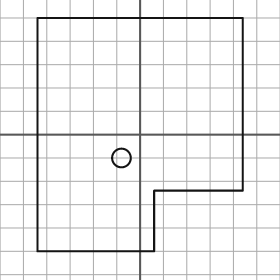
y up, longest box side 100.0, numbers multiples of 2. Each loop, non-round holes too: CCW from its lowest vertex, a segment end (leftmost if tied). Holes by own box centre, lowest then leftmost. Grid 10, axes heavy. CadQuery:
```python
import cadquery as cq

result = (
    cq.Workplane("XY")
    .moveTo(-44.0, -50.0)
    .lineTo(6.0, -50.0)
    .lineTo(6.0, -24.0)
    .lineTo(44.0, -24.0)
    .lineTo(44.0, 50.0)
    .lineTo(-44.0, 50.0)
    .close()
    .moveTo(-8.0, -10.0)
    .circle(4.0)
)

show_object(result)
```